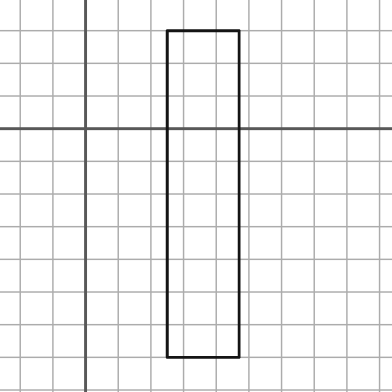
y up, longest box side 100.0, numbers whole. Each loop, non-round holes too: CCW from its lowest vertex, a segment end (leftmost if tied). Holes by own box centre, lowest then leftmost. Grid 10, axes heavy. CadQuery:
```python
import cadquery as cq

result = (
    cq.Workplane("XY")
    .moveTo(25.0, -70.0)
    .lineTo(47.0, -70.0)
    .lineTo(47.0, 30.0)
    .lineTo(25.0, 30.0)
    .close()
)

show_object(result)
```